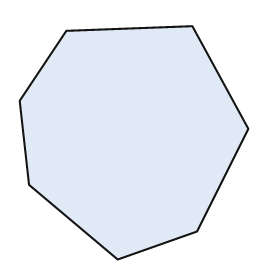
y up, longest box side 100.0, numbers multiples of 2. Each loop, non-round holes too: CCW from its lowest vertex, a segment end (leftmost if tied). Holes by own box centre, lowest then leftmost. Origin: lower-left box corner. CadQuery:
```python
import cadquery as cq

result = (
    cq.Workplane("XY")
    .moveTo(42.0, 0.0)
    .lineTo(76.0, 12.0)
    .lineTo(98.0, 56.0)
    .lineTo(74.0, 100.0)
    .lineTo(20.0, 98.0)
    .lineTo(0.0, 68.0)
    .lineTo(4.0, 32.0)
    .close()
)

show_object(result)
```